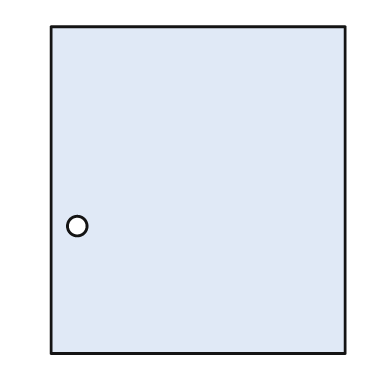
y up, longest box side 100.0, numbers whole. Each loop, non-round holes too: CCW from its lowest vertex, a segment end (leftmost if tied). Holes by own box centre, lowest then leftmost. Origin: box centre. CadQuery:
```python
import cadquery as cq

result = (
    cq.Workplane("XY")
    .moveTo(-45.0, -50.0)
    .lineTo(45.0, -50.0)
    .lineTo(45.0, 50.0)
    .lineTo(-45.0, 50.0)
    .close()
    .moveTo(-37.0, -11.0)
    .circle(3.0)
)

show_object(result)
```